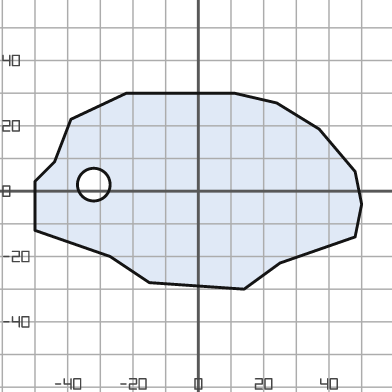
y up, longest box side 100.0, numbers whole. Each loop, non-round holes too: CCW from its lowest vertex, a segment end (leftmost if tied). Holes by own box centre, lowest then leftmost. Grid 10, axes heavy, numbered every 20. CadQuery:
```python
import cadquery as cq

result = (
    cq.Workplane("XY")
    .moveTo(14.0, -30.0)
    .lineTo(25.0, -22.0)
    .lineTo(48.0, -14.0)
    .lineTo(50.0, -4.0)
    .lineTo(48.0, 6.0)
    .lineTo(37.0, 19.0)
    .lineTo(24.0, 27.0)
    .lineTo(11.0, 30.0)
    .lineTo(-22.0, 30.0)
    .lineTo(-39.0, 22.0)
    .lineTo(-44.0, 9.0)
    .lineTo(-50.0, 3.0)
    .lineTo(-50.0, -12.0)
    .lineTo(-27.0, -20.0)
    .lineTo(-15.0, -28.0)
    .close()
    .moveTo(-32.0, 2.0)
    .circle(5.0)
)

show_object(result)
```